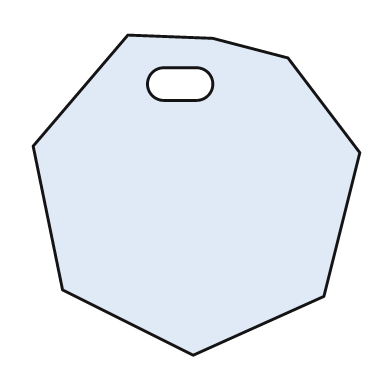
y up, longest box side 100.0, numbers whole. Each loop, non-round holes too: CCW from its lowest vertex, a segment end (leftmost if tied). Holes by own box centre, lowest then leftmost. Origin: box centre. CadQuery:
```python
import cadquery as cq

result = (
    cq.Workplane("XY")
    .moveTo(-1.0, -49.0)
    .lineTo(39.0, -31.0)
    .lineTo(50.0, 13.0)
    .lineTo(28.0, 42.0)
    .lineTo(5.0, 48.0)
    .lineTo(-21.0, 49.0)
    .lineTo(-50.0, 15.0)
    .lineTo(-41.0, -29.0)
    .close()
    .moveTo(-10.0, 29.0)
    .lineTo(0.0, 29.0)
    .threePointArc((5.0, 34.0), (0.0, 39.0))
    .lineTo(-10.0, 39.0)
    .threePointArc((-15.0, 34.0), (-10.0, 29.0))
    .close()
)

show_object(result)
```